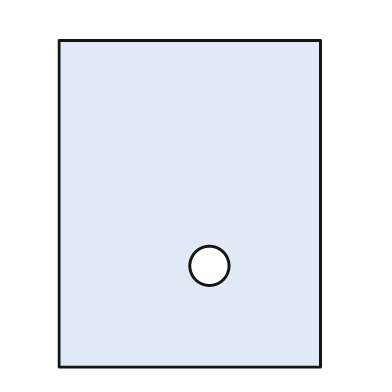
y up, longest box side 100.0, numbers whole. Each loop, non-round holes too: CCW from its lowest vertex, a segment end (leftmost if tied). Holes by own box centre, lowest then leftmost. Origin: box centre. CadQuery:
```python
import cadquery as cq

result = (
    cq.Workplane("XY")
    .moveTo(-40.0, -50.0)
    .lineTo(40.0, -50.0)
    .lineTo(40.0, 50.0)
    .lineTo(-40.0, 50.0)
    .close()
    .moveTo(6.0, -19.0)
    .circle(6.0)
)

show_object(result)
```